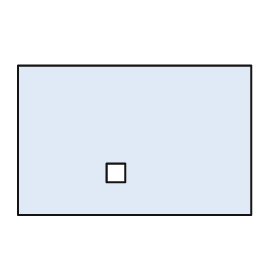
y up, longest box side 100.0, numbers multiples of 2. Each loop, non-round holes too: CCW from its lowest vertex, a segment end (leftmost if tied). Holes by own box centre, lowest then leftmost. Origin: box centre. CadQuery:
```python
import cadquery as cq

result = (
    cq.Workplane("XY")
    .moveTo(-50.0, -32.0)
    .lineTo(50.0, -32.0)
    .lineTo(50.0, 32.0)
    .lineTo(-50.0, 32.0)
    .close()
    .moveTo(-12.0, -18.0)
    .lineTo(-4.0, -18.0)
    .lineTo(-4.0, -10.0)
    .lineTo(-12.0, -10.0)
    .close()
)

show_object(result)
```